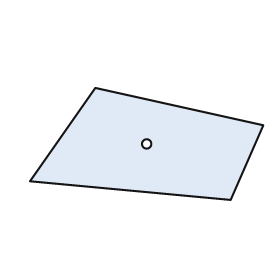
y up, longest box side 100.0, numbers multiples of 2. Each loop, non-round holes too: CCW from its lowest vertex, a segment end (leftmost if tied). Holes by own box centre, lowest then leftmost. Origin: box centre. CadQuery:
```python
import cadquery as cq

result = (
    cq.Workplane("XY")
    .moveTo(36.0, -24.0)
    .lineTo(50.0, 8.0)
    .lineTo(-22.0, 24.0)
    .lineTo(-50.0, -16.0)
    .close()
    .moveTo(0.0, 0.0)
    .circle(2.0)
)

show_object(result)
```